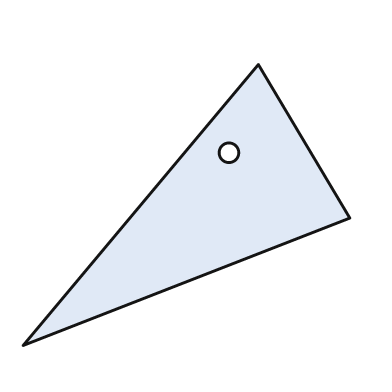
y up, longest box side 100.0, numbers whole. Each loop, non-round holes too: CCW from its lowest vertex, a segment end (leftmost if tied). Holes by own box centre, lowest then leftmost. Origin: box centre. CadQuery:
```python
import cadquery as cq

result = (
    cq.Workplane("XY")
    .moveTo(-50.0, -43.0)
    .lineTo(50.0, -4.0)
    .lineTo(22.0, 43.0)
    .close()
    .moveTo(13.0, 16.0)
    .circle(3.0)
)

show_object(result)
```